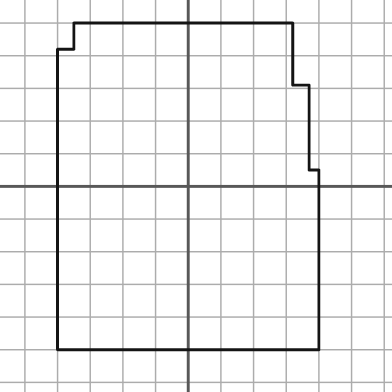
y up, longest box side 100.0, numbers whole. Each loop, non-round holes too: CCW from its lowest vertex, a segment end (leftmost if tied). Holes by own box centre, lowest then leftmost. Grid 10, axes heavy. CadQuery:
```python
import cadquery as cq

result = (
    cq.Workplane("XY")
    .moveTo(-40.0, -50.0)
    .lineTo(40.0, -50.0)
    .lineTo(40.0, 5.0)
    .lineTo(37.0, 5.0)
    .lineTo(37.0, 31.0)
    .lineTo(32.0, 31.0)
    .lineTo(32.0, 50.0)
    .lineTo(-35.0, 50.0)
    .lineTo(-35.0, 42.0)
    .lineTo(-40.0, 42.0)
    .close()
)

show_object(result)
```